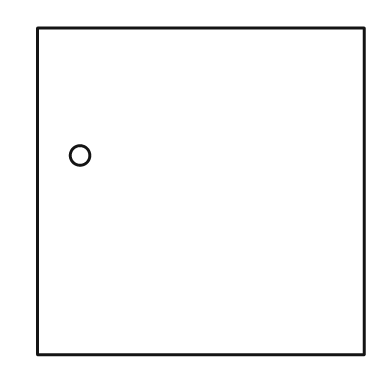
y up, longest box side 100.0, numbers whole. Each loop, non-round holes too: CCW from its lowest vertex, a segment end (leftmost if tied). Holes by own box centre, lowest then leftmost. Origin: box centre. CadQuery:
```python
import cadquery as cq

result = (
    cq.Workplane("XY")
    .moveTo(-50.0, -50.0)
    .lineTo(50.0, -50.0)
    .lineTo(50.0, 50.0)
    .lineTo(-50.0, 50.0)
    .close()
    .moveTo(-37.0, 11.0)
    .circle(3.0)
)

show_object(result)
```